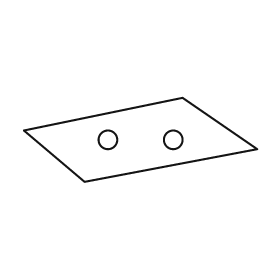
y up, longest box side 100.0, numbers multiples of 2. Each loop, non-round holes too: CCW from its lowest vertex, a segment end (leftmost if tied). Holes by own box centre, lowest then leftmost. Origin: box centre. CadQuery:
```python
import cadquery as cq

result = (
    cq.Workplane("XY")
    .moveTo(-24.0, -18.0)
    .lineTo(50.0, -4.0)
    .lineTo(18.0, 18.0)
    .lineTo(-50.0, 4.0)
    .close()
    .moveTo(-14.0, 0.0)
    .circle(4.0)
    .moveTo(14.0, 0.0)
    .circle(4.0)
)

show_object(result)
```